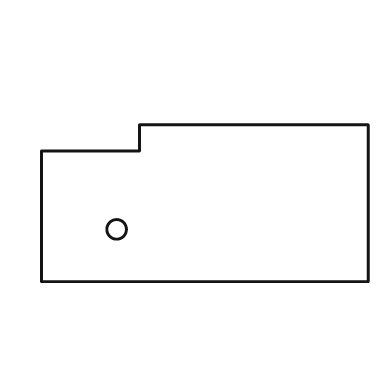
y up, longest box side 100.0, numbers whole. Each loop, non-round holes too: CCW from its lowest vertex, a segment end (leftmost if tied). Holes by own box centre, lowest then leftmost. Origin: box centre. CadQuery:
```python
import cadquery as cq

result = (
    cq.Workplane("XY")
    .moveTo(-50.0, -24.0)
    .lineTo(50.0, -24.0)
    .lineTo(50.0, 24.0)
    .lineTo(-20.0, 24.0)
    .lineTo(-20.0, 16.0)
    .lineTo(-50.0, 16.0)
    .close()
    .moveTo(-27.0, -8.0)
    .circle(3.0)
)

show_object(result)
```